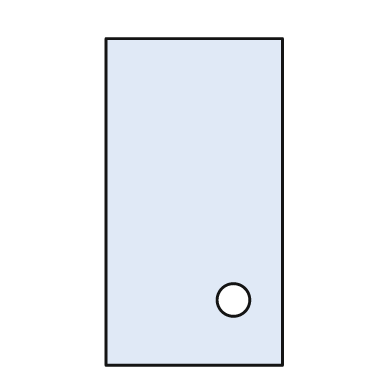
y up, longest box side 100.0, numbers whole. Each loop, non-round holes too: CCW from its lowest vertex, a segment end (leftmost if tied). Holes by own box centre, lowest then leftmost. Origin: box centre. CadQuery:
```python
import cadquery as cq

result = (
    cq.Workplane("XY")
    .moveTo(-27.0, -50.0)
    .lineTo(27.0, -50.0)
    .lineTo(27.0, 50.0)
    .lineTo(-27.0, 50.0)
    .close()
    .moveTo(12.0, -30.0)
    .circle(5.0)
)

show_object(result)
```